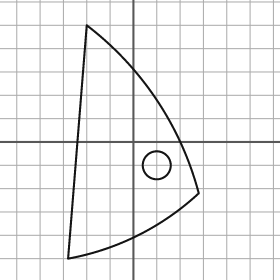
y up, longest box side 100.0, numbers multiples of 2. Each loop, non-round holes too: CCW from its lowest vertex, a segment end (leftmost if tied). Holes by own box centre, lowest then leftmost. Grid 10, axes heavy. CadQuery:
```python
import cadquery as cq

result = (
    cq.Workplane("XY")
    .moveTo(-28.0, -50.0)
    .threePointArc((2.0, -40.0), (28.0, -22.0))
    .threePointArc((10.0, 18.0), (-20.0, 50.0))
    .close()
    .moveTo(10.0, -10.0)
    .circle(6.0)
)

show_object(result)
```